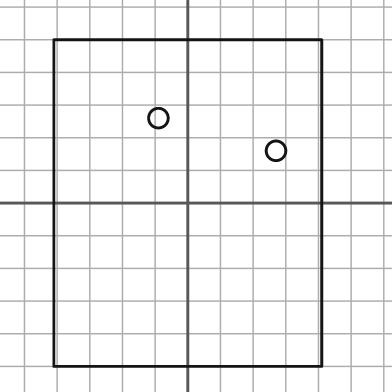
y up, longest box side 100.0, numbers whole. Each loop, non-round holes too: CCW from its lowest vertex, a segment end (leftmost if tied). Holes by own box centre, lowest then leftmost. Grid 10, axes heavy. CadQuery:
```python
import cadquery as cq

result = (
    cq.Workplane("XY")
    .moveTo(-41.0, -50.0)
    .lineTo(41.0, -50.0)
    .lineTo(41.0, 50.0)
    .lineTo(-41.0, 50.0)
    .close()
    .moveTo(27.0, 16.0)
    .circle(3.0)
    .moveTo(-9.0, 26.0)
    .circle(3.0)
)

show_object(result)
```